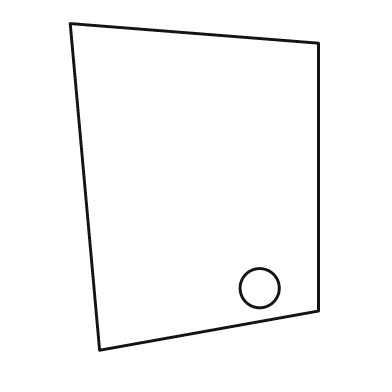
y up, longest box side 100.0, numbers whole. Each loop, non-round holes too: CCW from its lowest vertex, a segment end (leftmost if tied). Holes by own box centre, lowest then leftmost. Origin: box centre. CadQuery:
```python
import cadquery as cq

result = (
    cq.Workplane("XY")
    .moveTo(-29.0, -50.0)
    .lineTo(38.0, -38.0)
    .lineTo(38.0, 44.0)
    .lineTo(-38.0, 50.0)
    .close()
    .moveTo(20.0, -31.0)
    .circle(6.0)
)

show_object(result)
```